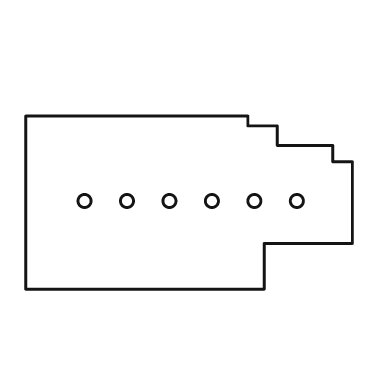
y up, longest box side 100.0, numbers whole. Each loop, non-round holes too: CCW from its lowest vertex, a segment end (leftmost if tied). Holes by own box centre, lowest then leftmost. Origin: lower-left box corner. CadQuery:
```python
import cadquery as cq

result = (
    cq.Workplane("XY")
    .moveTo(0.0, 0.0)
    .lineTo(73.0, 0.0)
    .lineTo(73.0, 14.0)
    .lineTo(100.0, 14.0)
    .lineTo(100.0, 39.0)
    .lineTo(94.0, 39.0)
    .lineTo(94.0, 44.0)
    .lineTo(77.0, 44.0)
    .lineTo(77.0, 50.0)
    .lineTo(68.0, 50.0)
    .lineTo(68.0, 53.0)
    .lineTo(0.0, 53.0)
    .close()
    .moveTo(18.0, 27.0)
    .circle(2.0)
    .moveTo(31.0, 27.0)
    .circle(2.0)
    .moveTo(44.0, 27.0)
    .circle(2.0)
    .moveTo(57.0, 27.0)
    .circle(2.0)
    .moveTo(70.0, 27.0)
    .circle(2.0)
    .moveTo(83.0, 27.0)
    .circle(2.0)
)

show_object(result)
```